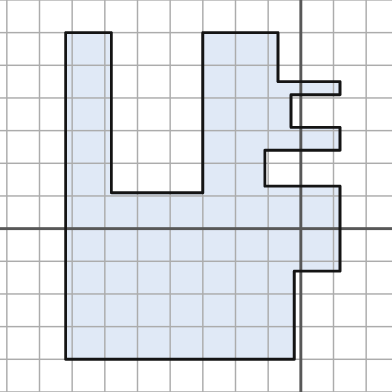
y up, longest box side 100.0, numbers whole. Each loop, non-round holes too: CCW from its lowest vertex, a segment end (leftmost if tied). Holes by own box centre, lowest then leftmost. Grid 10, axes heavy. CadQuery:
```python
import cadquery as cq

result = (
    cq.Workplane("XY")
    .moveTo(-72.0, -40.0)
    .lineTo(-2.0, -40.0)
    .lineTo(-2.0, -13.0)
    .lineTo(12.0, -13.0)
    .lineTo(12.0, 13.0)
    .lineTo(-11.0, 13.0)
    .lineTo(-11.0, 24.0)
    .lineTo(12.0, 24.0)
    .lineTo(12.0, 31.0)
    .lineTo(-3.0, 31.0)
    .lineTo(-3.0, 41.0)
    .lineTo(12.0, 41.0)
    .lineTo(12.0, 45.0)
    .lineTo(-7.0, 45.0)
    .lineTo(-7.0, 60.0)
    .lineTo(-30.0, 60.0)
    .lineTo(-30.0, 11.0)
    .lineTo(-58.0, 11.0)
    .lineTo(-58.0, 60.0)
    .lineTo(-72.0, 60.0)
    .close()
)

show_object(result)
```